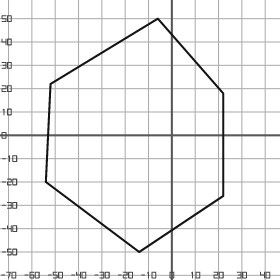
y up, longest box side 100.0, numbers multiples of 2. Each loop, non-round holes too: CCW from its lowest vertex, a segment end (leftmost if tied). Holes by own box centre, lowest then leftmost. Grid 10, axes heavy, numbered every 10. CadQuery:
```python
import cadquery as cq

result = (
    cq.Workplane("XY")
    .moveTo(-14.0, -50.0)
    .lineTo(22.0, -26.0)
    .lineTo(22.0, 18.0)
    .lineTo(-6.0, 50.0)
    .lineTo(-52.0, 22.0)
    .lineTo(-54.0, -20.0)
    .close()
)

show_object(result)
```